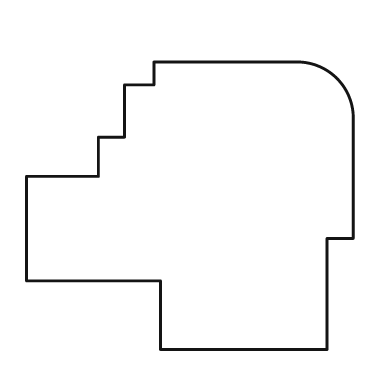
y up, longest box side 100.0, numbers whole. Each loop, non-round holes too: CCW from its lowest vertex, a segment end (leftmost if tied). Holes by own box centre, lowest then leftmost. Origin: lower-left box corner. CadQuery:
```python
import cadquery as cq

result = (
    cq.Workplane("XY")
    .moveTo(41.0, 0.0)
    .lineTo(92.0, 0.0)
    .lineTo(92.0, 34.0)
    .lineTo(100.0, 34.0)
    .lineTo(100.0, 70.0)
    .threePointArc((95.0, 83.0), (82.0, 88.0))
    .lineTo(39.0, 88.0)
    .lineTo(39.0, 81.0)
    .lineTo(30.0, 81.0)
    .lineTo(30.0, 65.0)
    .lineTo(22.0, 65.0)
    .lineTo(22.0, 53.0)
    .lineTo(0.0, 53.0)
    .lineTo(0.0, 21.0)
    .lineTo(41.0, 21.0)
    .close()
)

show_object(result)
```